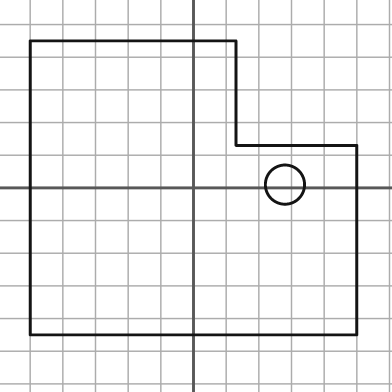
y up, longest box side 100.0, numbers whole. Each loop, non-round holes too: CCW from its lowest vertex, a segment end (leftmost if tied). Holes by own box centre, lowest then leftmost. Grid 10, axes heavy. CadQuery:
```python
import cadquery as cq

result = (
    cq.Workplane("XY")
    .moveTo(-50.0, -45.0)
    .lineTo(50.0, -45.0)
    .lineTo(50.0, 13.0)
    .lineTo(13.0, 13.0)
    .lineTo(13.0, 45.0)
    .lineTo(-50.0, 45.0)
    .close()
    .moveTo(28.0, 1.0)
    .circle(6.0)
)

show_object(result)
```